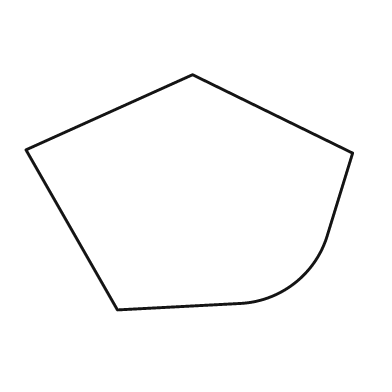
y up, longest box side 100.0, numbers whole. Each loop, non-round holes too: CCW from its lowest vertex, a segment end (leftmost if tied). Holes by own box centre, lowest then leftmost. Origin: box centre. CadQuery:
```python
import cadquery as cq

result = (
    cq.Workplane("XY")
    .moveTo(-22.0, -36.0)
    .lineTo(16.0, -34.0)
    .threePointArc((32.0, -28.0), (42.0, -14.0))
    .lineTo(50.0, 12.0)
    .lineTo(1.0, 36.0)
    .lineTo(-50.0, 13.0)
    .close()
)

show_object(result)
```